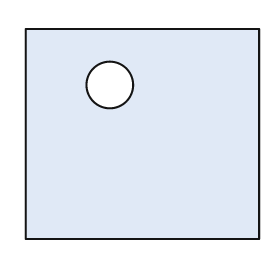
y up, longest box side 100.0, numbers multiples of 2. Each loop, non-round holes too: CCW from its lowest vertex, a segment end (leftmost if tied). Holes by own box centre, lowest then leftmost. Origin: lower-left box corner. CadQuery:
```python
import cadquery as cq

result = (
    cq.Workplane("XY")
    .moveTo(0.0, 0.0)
    .lineTo(100.0, 0.0)
    .lineTo(100.0, 90.0)
    .lineTo(0.0, 90.0)
    .close()
    .moveTo(36.0, 66.0)
    .circle(10.0)
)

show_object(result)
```